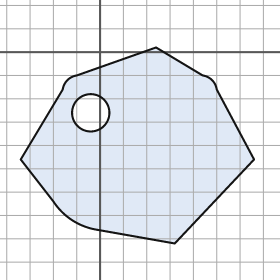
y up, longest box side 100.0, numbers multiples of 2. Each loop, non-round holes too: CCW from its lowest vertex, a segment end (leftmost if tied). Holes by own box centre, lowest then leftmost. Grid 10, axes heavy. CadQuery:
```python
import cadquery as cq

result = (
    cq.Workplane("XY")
    .moveTo(32.0, -82.0)
    .lineTo(66.0, -46.0)
    .lineTo(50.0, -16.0)
    .threePointArc((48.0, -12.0), (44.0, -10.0))
    .lineTo(24.0, 2.0)
    .lineTo(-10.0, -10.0)
    .threePointArc((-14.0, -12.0), (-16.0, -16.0))
    .lineTo(-34.0, -46.0)
    .lineTo(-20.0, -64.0)
    .threePointArc((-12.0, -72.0), (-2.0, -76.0))
    .close()
    .moveTo(-4.0, -26.0)
    .circle(8.0)
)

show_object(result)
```